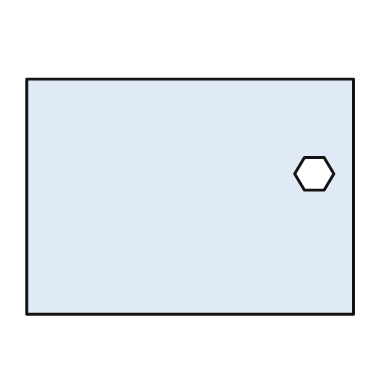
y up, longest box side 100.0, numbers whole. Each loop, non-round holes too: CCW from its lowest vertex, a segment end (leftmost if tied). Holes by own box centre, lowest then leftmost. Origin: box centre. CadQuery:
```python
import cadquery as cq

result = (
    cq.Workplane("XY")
    .moveTo(-50.0, -36.0)
    .lineTo(50.0, -36.0)
    .lineTo(50.0, 36.0)
    .lineTo(-50.0, 36.0)
    .close()
    .moveTo(35.0, 2.0)
    .lineTo(41.0, 2.0)
    .lineTo(44.0, 7.0)
    .lineTo(41.0, 12.0)
    .lineTo(35.0, 12.0)
    .lineTo(32.0, 7.0)
    .close()
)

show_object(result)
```